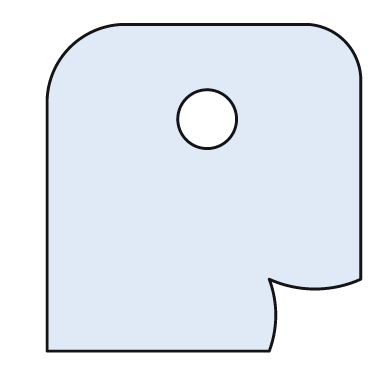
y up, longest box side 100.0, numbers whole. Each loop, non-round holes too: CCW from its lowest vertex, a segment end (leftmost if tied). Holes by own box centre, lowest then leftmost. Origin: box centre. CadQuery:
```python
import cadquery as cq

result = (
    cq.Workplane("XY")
    .moveTo(-48.0, -50.0)
    .lineTo(20.0, -50.0)
    .threePointArc((22.0, -39.0), (20.0, -28.0))
    .threePointArc((34.0, -31.0), (48.0, -28.0))
    .lineTo(48.0, 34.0)
    .threePointArc((43.0, 45.0), (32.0, 50.0))
    .lineTo(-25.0, 50.0)
    .threePointArc((-41.0, 43.0), (-48.0, 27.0))
    .close()
    .moveTo(1.0, 21.0)
    .circle(9.0)
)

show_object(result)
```